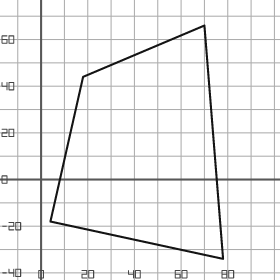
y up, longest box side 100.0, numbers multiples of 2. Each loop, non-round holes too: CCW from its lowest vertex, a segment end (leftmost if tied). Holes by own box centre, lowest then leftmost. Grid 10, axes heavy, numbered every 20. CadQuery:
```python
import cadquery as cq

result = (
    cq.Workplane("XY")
    .moveTo(78.0, -34.0)
    .lineTo(70.0, 66.0)
    .lineTo(18.0, 44.0)
    .lineTo(4.0, -18.0)
    .close()
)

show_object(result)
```